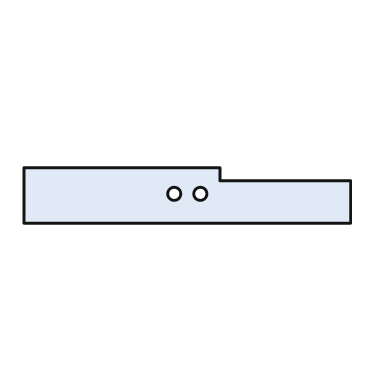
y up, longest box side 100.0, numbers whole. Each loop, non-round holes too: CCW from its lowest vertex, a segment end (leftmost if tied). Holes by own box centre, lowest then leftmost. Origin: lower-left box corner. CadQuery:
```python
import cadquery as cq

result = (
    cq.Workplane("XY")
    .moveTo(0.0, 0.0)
    .lineTo(100.0, 0.0)
    .lineTo(100.0, 13.0)
    .lineTo(60.0, 13.0)
    .lineTo(60.0, 17.0)
    .lineTo(0.0, 17.0)
    .close()
    .moveTo(46.0, 9.0)
    .circle(2.0)
    .moveTo(54.0, 9.0)
    .circle(2.0)
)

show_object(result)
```